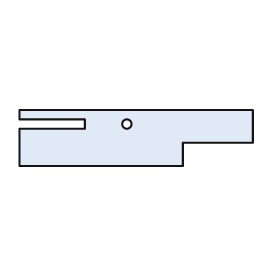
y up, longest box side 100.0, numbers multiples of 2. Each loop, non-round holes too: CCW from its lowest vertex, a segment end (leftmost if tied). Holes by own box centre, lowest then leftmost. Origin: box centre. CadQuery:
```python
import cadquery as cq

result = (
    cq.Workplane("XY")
    .moveTo(-50.0, -12.0)
    .lineTo(20.0, -12.0)
    .lineTo(20.0, -2.0)
    .lineTo(50.0, -2.0)
    .lineTo(50.0, 12.0)
    .lineTo(-50.0, 12.0)
    .lineTo(-50.0, 8.0)
    .lineTo(-22.0, 8.0)
    .lineTo(-22.0, 4.0)
    .lineTo(-50.0, 4.0)
    .close()
    .moveTo(-4.0, 6.0)
    .circle(2.0)
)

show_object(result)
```